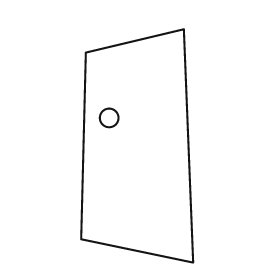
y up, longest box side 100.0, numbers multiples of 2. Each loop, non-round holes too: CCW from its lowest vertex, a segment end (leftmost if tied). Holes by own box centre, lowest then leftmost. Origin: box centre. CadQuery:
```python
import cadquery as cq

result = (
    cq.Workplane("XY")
    .moveTo(24.0, -50.0)
    .lineTo(20.0, 50.0)
    .lineTo(-22.0, 40.0)
    .lineTo(-24.0, -40.0)
    .close()
    .moveTo(-12.0, 12.0)
    .circle(4.0)
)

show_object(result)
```